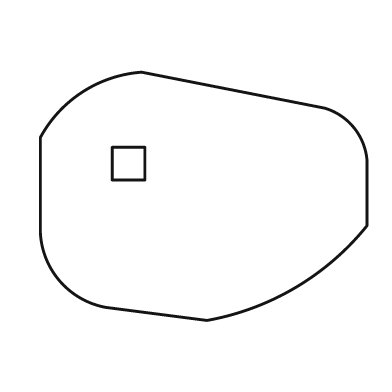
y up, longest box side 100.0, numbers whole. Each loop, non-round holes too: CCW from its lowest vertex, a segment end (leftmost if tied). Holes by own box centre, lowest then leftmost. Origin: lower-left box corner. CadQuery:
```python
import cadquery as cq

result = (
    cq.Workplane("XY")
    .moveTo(51.0, 0.0)
    .threePointArc((78.0, 10.0), (100.0, 29.0))
    .lineTo(100.0, 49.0)
    .threePointArc((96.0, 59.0), (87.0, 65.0))
    .lineTo(31.0, 76.0)
    .threePointArc((13.0, 70.0), (0.0, 56.0))
    .lineTo(0.0, 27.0)
    .threePointArc((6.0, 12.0), (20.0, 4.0))
    .close()
    .moveTo(22.0, 43.0)
    .lineTo(32.0, 43.0)
    .lineTo(32.0, 53.0)
    .lineTo(22.0, 53.0)
    .close()
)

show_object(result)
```